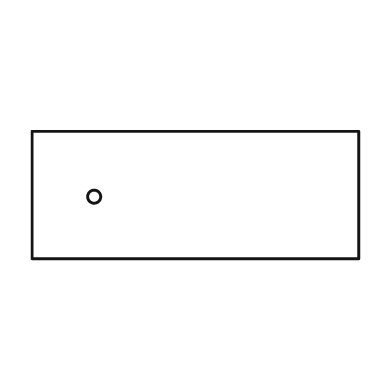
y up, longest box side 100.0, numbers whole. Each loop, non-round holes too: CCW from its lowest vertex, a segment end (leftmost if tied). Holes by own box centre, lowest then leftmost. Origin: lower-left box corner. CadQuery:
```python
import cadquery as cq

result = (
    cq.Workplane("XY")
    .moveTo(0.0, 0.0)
    .lineTo(100.0, 0.0)
    .lineTo(100.0, 39.0)
    .lineTo(0.0, 39.0)
    .close()
    .moveTo(19.0, 19.0)
    .circle(2.0)
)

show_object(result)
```